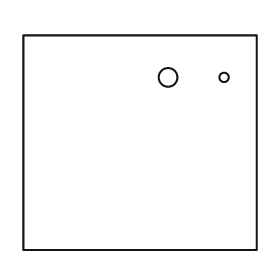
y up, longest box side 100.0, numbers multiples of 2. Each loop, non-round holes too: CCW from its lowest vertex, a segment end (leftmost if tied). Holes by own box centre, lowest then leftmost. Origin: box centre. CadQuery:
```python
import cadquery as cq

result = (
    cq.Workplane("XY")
    .moveTo(-50.0, -46.0)
    .lineTo(50.0, -46.0)
    .lineTo(50.0, 46.0)
    .lineTo(-50.0, 46.0)
    .close()
    .moveTo(12.0, 28.0)
    .circle(4.0)
    .moveTo(36.0, 28.0)
    .circle(2.0)
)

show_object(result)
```